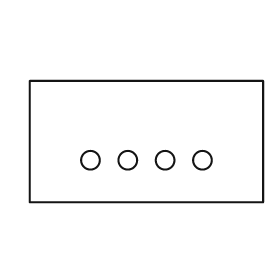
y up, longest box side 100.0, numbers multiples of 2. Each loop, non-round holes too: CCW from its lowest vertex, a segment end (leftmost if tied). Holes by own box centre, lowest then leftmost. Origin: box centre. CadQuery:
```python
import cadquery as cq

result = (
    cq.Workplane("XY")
    .moveTo(-50.0, -26.0)
    .lineTo(50.0, -26.0)
    .lineTo(50.0, 26.0)
    .lineTo(-50.0, 26.0)
    .close()
    .moveTo(-24.0, -8.0)
    .circle(4.0)
    .moveTo(-8.0, -8.0)
    .circle(4.0)
    .moveTo(8.0, -8.0)
    .circle(4.0)
    .moveTo(24.0, -8.0)
    .circle(4.0)
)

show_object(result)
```